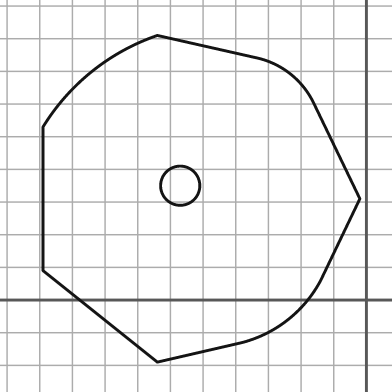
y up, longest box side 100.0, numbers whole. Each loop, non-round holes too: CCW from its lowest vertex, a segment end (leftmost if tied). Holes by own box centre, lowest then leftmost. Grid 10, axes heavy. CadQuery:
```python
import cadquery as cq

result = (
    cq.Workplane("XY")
    .moveTo(-64.0, -19.0)
    .lineTo(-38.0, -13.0)
    .threePointArc((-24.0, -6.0), (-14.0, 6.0))
    .lineTo(-2.0, 31.0)
    .lineTo(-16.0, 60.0)
    .threePointArc((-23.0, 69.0), (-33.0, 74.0))
    .lineTo(-64.0, 81.0)
    .threePointArc((-84.0, 70.0), (-99.0, 53.0))
    .lineTo(-99.0, 9.0)
    .close()
    .moveTo(-57.0, 35.0)
    .circle(6.0)
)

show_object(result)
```